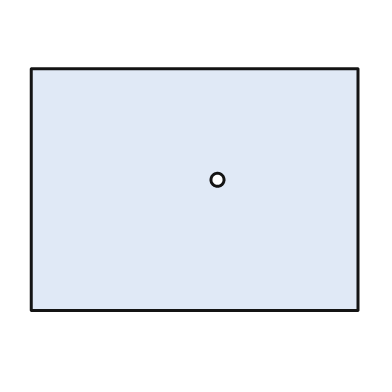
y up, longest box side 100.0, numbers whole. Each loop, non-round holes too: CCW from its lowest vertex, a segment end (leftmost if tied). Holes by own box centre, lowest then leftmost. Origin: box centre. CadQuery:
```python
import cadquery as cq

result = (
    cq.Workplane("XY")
    .moveTo(-50.0, -37.0)
    .lineTo(50.0, -37.0)
    .lineTo(50.0, 37.0)
    .lineTo(-50.0, 37.0)
    .close()
    .moveTo(7.0, 3.0)
    .circle(2.0)
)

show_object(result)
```